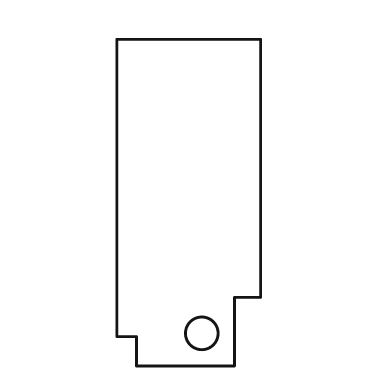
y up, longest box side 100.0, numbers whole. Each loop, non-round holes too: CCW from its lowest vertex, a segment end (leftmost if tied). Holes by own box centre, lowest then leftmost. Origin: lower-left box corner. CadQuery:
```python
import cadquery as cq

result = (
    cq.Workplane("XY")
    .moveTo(6.0, 0.0)
    .lineTo(36.0, 0.0)
    .lineTo(36.0, 21.0)
    .lineTo(44.0, 21.0)
    .lineTo(44.0, 100.0)
    .lineTo(0.0, 100.0)
    .lineTo(0.0, 9.0)
    .lineTo(6.0, 9.0)
    .close()
    .moveTo(26.0, 10.0)
    .circle(5.0)
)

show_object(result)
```